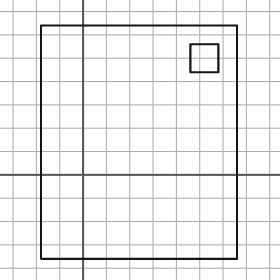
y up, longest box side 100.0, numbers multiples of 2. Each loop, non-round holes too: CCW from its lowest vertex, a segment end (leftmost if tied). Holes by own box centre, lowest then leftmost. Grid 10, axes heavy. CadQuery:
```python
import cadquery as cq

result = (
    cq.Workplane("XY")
    .moveTo(-18.0, -36.0)
    .lineTo(66.0, -36.0)
    .lineTo(66.0, 64.0)
    .lineTo(-18.0, 64.0)
    .close()
    .moveTo(46.0, 44.0)
    .lineTo(58.0, 44.0)
    .lineTo(58.0, 56.0)
    .lineTo(46.0, 56.0)
    .close()
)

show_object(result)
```